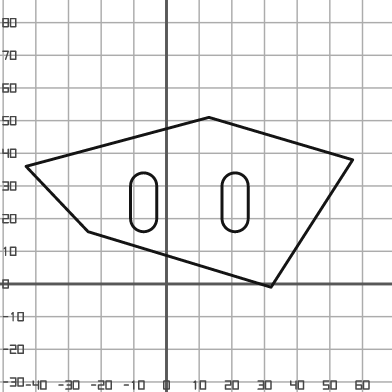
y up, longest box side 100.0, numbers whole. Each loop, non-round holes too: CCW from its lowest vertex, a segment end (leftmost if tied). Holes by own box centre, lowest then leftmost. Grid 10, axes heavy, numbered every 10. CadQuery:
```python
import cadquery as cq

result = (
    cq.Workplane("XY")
    .moveTo(32.0, -1.0)
    .lineTo(57.0, 38.0)
    .lineTo(13.0, 51.0)
    .lineTo(-43.0, 36.0)
    .lineTo(-24.0, 16.0)
    .close()
    .moveTo(-11.0, 20.0)
    .threePointArc((-7.0, 16.0), (-3.0, 20.0))
    .lineTo(-3.0, 30.0)
    .threePointArc((-7.0, 34.0), (-11.0, 30.0))
    .close()
    .moveTo(17.0, 20.0)
    .threePointArc((21.0, 16.0), (25.0, 20.0))
    .lineTo(25.0, 30.0)
    .threePointArc((21.0, 34.0), (17.0, 30.0))
    .close()
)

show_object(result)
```